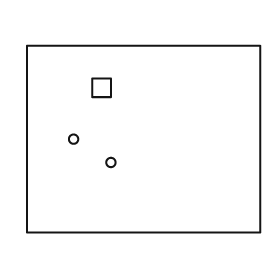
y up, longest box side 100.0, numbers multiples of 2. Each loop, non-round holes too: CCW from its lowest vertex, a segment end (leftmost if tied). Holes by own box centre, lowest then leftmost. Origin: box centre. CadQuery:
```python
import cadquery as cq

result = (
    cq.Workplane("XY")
    .moveTo(-50.0, -40.0)
    .lineTo(50.0, -40.0)
    .lineTo(50.0, 40.0)
    .lineTo(-50.0, 40.0)
    .close()
    .moveTo(-14.0, -10.0)
    .circle(2.0)
    .moveTo(-30.0, 0.0)
    .circle(2.0)
    .moveTo(-22.0, 18.0)
    .lineTo(-14.0, 18.0)
    .lineTo(-14.0, 26.0)
    .lineTo(-22.0, 26.0)
    .close()
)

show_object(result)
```